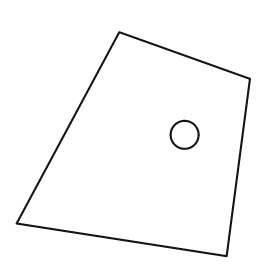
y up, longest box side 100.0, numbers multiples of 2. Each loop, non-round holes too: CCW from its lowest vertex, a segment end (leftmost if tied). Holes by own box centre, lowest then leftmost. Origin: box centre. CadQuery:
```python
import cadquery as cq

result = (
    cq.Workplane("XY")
    .moveTo(40.0, -48.0)
    .lineTo(50.0, 28.0)
    .lineTo(-6.0, 48.0)
    .lineTo(-50.0, -34.0)
    .close()
    .moveTo(22.0, 4.0)
    .circle(6.0)
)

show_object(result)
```